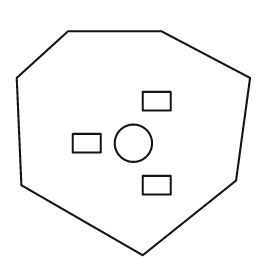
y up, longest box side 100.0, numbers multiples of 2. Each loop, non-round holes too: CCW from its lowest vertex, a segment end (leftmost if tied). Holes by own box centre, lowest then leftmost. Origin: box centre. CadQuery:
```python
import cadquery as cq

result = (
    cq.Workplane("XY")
    .moveTo(4.0, -48.0)
    .lineTo(44.0, -16.0)
    .lineTo(50.0, 28.0)
    .lineTo(12.0, 48.0)
    .lineTo(-28.0, 48.0)
    .lineTo(-50.0, 28.0)
    .lineTo(-48.0, -18.0)
    .close()
    .moveTo(4.0, -22.0)
    .lineTo(16.0, -22.0)
    .lineTo(16.0, -14.0)
    .lineTo(4.0, -14.0)
    .close()
    .moveTo(-26.0, -4.0)
    .lineTo(-14.0, -4.0)
    .lineTo(-14.0, 4.0)
    .lineTo(-26.0, 4.0)
    .close()
    .moveTo(0.0, 0.0)
    .circle(8.0)
    .moveTo(4.0, 14.0)
    .lineTo(16.0, 14.0)
    .lineTo(16.0, 22.0)
    .lineTo(4.0, 22.0)
    .close()
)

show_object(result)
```